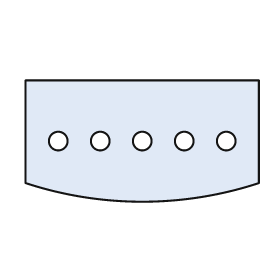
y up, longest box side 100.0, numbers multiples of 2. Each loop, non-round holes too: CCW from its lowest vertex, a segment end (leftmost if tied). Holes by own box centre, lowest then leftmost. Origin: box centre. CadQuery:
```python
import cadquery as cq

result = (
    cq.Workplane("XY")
    .moveTo(-50.0, -18.0)
    .threePointArc((0.0, -26.0), (50.0, -18.0))
    .lineTo(50.0, 26.0)
    .lineTo(-50.0, 26.0)
    .close()
    .moveTo(-36.0, 0.0)
    .circle(4.0)
    .moveTo(-18.0, 0.0)
    .circle(4.0)
    .moveTo(0.0, 0.0)
    .circle(4.0)
    .moveTo(18.0, 0.0)
    .circle(4.0)
    .moveTo(36.0, 0.0)
    .circle(4.0)
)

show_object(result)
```